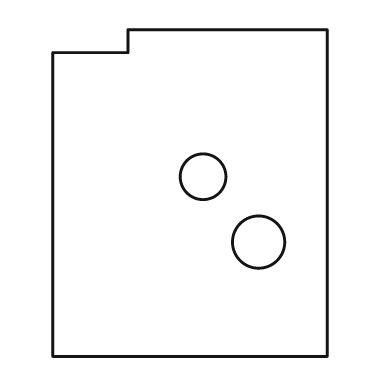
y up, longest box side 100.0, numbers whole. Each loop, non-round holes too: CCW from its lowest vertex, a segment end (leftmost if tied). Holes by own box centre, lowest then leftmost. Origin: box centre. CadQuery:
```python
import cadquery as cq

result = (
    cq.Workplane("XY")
    .moveTo(-42.0, -50.0)
    .lineTo(42.0, -50.0)
    .lineTo(42.0, 50.0)
    .lineTo(-19.0, 50.0)
    .lineTo(-19.0, 43.0)
    .lineTo(-42.0, 43.0)
    .close()
    .moveTo(21.0, -15.0)
    .circle(8.0)
    .moveTo(4.0, 5.0)
    .circle(7.0)
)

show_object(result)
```